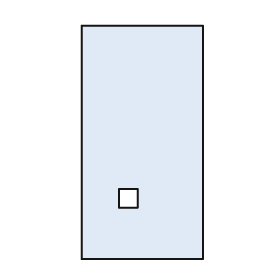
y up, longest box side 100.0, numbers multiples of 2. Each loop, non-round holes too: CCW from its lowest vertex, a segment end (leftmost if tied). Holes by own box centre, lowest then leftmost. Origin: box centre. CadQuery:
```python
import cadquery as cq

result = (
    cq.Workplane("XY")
    .moveTo(-26.0, -50.0)
    .lineTo(26.0, -50.0)
    .lineTo(26.0, 50.0)
    .lineTo(-26.0, 50.0)
    .close()
    .moveTo(-10.0, -28.0)
    .lineTo(-2.0, -28.0)
    .lineTo(-2.0, -20.0)
    .lineTo(-10.0, -20.0)
    .close()
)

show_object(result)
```